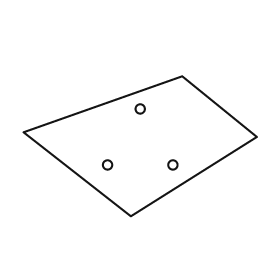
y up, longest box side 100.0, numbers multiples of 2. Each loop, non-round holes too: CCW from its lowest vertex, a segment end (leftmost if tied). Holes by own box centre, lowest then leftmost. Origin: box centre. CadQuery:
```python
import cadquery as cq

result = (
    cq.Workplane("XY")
    .moveTo(-4.0, -30.0)
    .lineTo(50.0, 4.0)
    .lineTo(18.0, 30.0)
    .lineTo(-50.0, 6.0)
    .close()
    .moveTo(-14.0, -8.0)
    .circle(2.0)
    .moveTo(14.0, -8.0)
    .circle(2.0)
    .moveTo(0.0, 16.0)
    .circle(2.0)
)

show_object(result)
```